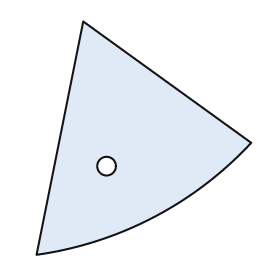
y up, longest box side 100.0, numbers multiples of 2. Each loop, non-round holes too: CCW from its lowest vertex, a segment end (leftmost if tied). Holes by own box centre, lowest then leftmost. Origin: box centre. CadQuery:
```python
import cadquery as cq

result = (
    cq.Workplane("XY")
    .moveTo(-46.0, -50.0)
    .threePointArc((4.0, -34.0), (46.0, -2.0))
    .lineTo(-26.0, 50.0)
    .close()
    .moveTo(-16.0, -12.0)
    .circle(4.0)
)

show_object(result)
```